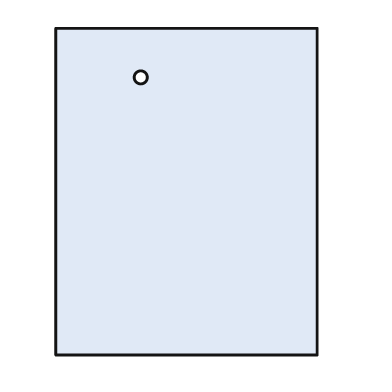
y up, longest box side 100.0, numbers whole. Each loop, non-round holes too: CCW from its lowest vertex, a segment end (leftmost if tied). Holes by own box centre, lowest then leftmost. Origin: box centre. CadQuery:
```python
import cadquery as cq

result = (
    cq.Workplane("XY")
    .moveTo(-40.0, -50.0)
    .lineTo(40.0, -50.0)
    .lineTo(40.0, 50.0)
    .lineTo(-40.0, 50.0)
    .close()
    .moveTo(-14.0, 35.0)
    .circle(2.0)
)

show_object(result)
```